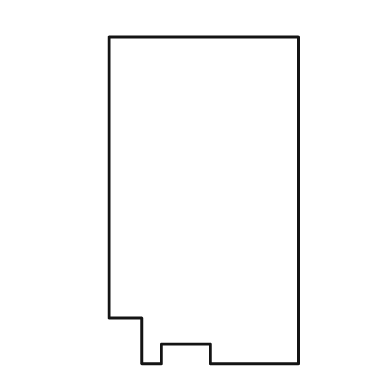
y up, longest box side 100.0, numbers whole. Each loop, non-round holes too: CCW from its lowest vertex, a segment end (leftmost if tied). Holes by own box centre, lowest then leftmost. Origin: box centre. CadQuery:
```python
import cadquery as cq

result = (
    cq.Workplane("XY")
    .moveTo(-19.0, -50.0)
    .lineTo(-13.0, -50.0)
    .lineTo(-13.0, -44.0)
    .lineTo(2.0, -44.0)
    .lineTo(2.0, -50.0)
    .lineTo(29.0, -50.0)
    .lineTo(29.0, 50.0)
    .lineTo(-29.0, 50.0)
    .lineTo(-29.0, -36.0)
    .lineTo(-19.0, -36.0)
    .close()
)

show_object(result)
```